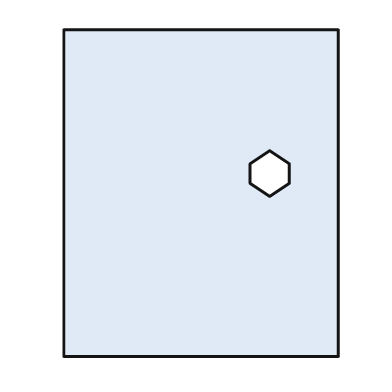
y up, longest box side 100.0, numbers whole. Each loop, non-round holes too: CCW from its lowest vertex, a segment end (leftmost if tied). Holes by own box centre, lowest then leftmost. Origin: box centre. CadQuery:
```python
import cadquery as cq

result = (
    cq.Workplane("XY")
    .moveTo(-42.0, -50.0)
    .lineTo(42.0, -50.0)
    .lineTo(42.0, 50.0)
    .lineTo(-42.0, 50.0)
    .close()
    .moveTo(21.0, -1.0)
    .lineTo(27.0, 3.0)
    .lineTo(27.0, 9.0)
    .lineTo(21.0, 13.0)
    .lineTo(15.0, 9.0)
    .lineTo(15.0, 3.0)
    .close()
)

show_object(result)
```